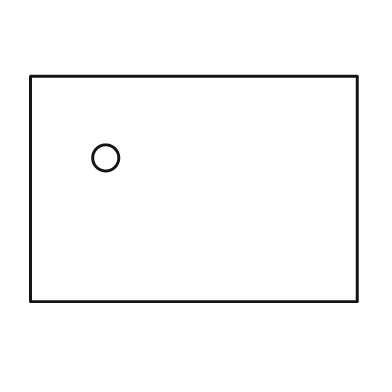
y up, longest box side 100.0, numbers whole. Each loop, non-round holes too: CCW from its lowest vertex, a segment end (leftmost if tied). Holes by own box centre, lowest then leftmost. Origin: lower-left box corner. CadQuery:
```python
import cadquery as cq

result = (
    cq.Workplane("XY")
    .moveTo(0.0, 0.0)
    .lineTo(100.0, 0.0)
    .lineTo(100.0, 69.0)
    .lineTo(0.0, 69.0)
    .close()
    .moveTo(23.0, 44.0)
    .circle(4.0)
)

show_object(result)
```